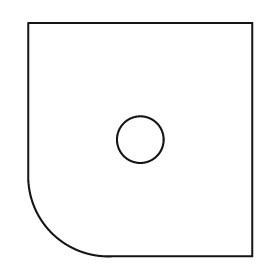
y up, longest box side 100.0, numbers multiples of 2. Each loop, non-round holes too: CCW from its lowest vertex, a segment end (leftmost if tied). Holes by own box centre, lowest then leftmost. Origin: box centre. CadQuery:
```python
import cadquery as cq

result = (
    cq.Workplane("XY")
    .moveTo(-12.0, -50.0)
    .lineTo(48.0, -50.0)
    .lineTo(48.0, 50.0)
    .lineTo(-48.0, 50.0)
    .lineTo(-48.0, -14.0)
    .threePointArc((-38.0, -40.0), (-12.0, -50.0))
    .close()
    .moveTo(0.0, 0.0)
    .circle(10.0)
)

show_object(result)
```